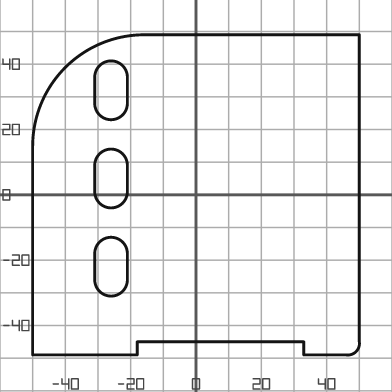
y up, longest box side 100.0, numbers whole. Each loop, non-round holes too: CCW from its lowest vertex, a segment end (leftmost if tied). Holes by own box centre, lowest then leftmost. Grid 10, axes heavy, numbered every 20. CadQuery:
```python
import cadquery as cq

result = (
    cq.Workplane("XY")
    .moveTo(-50.0, -49.0)
    .lineTo(-18.0, -49.0)
    .lineTo(-18.0, -45.0)
    .lineTo(33.0, -45.0)
    .lineTo(33.0, -49.0)
    .lineTo(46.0, -49.0)
    .threePointArc((49.0, -48.0), (50.0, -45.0))
    .lineTo(50.0, 49.0)
    .lineTo(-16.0, 49.0)
    .threePointArc((-40.0, 39.0), (-50.0, 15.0))
    .close()
    .moveTo(-31.0, -26.0)
    .threePointArc((-26.0, -31.0), (-21.0, -26.0))
    .lineTo(-21.0, -18.0)
    .threePointArc((-26.0, -13.0), (-31.0, -18.0))
    .close()
    .moveTo(-31.0, 1.0)
    .threePointArc((-26.0, -4.0), (-21.0, 1.0))
    .lineTo(-21.0, 9.0)
    .threePointArc((-26.0, 14.0), (-31.0, 9.0))
    .close()
    .moveTo(-31.0, 28.0)
    .threePointArc((-26.0, 23.0), (-21.0, 28.0))
    .lineTo(-21.0, 36.0)
    .threePointArc((-26.0, 41.0), (-31.0, 36.0))
    .close()
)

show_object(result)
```